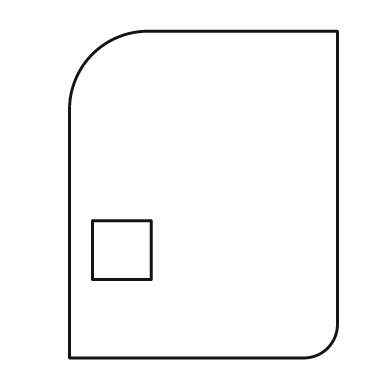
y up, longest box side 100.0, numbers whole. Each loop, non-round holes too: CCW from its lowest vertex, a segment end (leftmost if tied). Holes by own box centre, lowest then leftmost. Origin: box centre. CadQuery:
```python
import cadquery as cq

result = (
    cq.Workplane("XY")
    .moveTo(-41.0, -50.0)
    .lineTo(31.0, -50.0)
    .threePointArc((38.0, -47.0), (41.0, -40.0))
    .lineTo(41.0, 50.0)
    .lineTo(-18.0, 50.0)
    .threePointArc((-34.0, 43.0), (-41.0, 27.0))
    .close()
    .moveTo(-34.0, -26.0)
    .lineTo(-16.0, -26.0)
    .lineTo(-16.0, -8.0)
    .lineTo(-34.0, -8.0)
    .close()
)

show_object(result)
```